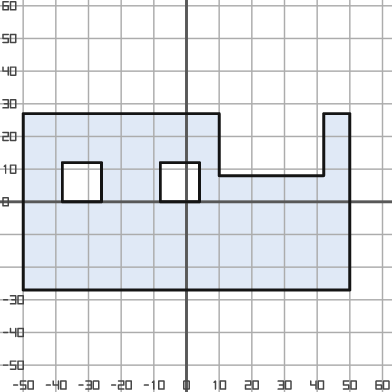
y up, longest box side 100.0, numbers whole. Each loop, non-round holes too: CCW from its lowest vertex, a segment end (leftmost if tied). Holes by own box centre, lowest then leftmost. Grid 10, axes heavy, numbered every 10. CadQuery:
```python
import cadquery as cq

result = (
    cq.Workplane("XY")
    .moveTo(-50.0, -27.0)
    .lineTo(50.0, -27.0)
    .lineTo(50.0, 27.0)
    .lineTo(42.0, 27.0)
    .lineTo(42.0, 8.0)
    .lineTo(10.0, 8.0)
    .lineTo(10.0, 27.0)
    .lineTo(-50.0, 27.0)
    .close()
    .moveTo(-38.0, 0.0)
    .lineTo(-26.0, 0.0)
    .lineTo(-26.0, 12.0)
    .lineTo(-38.0, 12.0)
    .close()
    .moveTo(-8.0, 0.0)
    .lineTo(4.0, 0.0)
    .lineTo(4.0, 12.0)
    .lineTo(-8.0, 12.0)
    .close()
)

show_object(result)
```